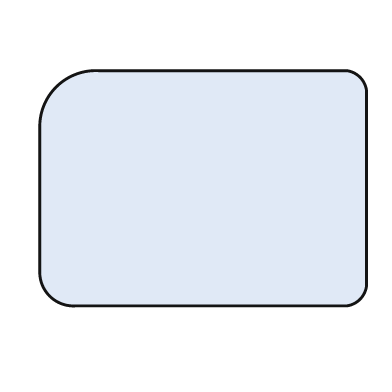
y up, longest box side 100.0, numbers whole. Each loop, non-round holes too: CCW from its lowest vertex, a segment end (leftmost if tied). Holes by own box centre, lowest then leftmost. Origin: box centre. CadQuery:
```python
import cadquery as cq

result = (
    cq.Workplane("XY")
    .moveTo(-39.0, -36.0)
    .lineTo(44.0, -36.0)
    .threePointArc((48.0, -34.0), (50.0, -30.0))
    .lineTo(50.0, 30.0)
    .threePointArc((48.0, 34.0), (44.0, 36.0))
    .lineTo(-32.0, 36.0)
    .threePointArc((-45.0, 31.0), (-50.0, 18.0))
    .lineTo(-50.0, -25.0)
    .threePointArc((-47.0, -33.0), (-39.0, -36.0))
    .close()
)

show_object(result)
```